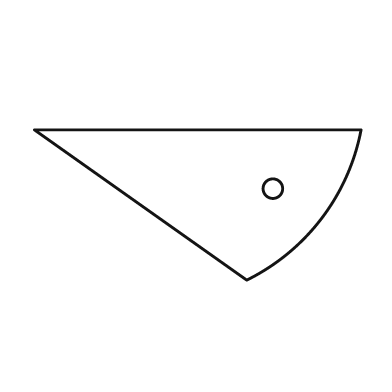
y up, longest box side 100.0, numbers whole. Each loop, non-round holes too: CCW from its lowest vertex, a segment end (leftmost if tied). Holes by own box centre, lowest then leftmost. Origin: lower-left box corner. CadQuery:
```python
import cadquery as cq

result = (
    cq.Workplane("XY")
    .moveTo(65.0, 0.0)
    .threePointArc((88.0, 19.0), (100.0, 46.0))
    .lineTo(0.0, 46.0)
    .close()
    .moveTo(73.0, 28.0)
    .circle(3.0)
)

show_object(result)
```